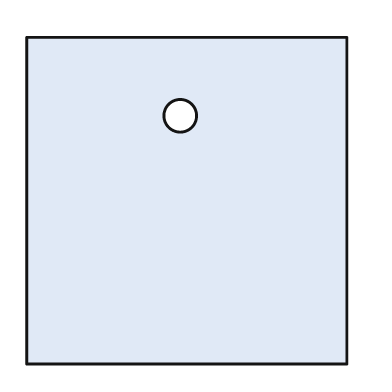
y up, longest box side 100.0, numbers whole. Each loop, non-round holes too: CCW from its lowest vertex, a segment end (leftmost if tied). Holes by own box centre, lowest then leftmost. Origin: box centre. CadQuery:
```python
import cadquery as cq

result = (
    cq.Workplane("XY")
    .moveTo(-49.0, -50.0)
    .lineTo(49.0, -50.0)
    .lineTo(49.0, 50.0)
    .lineTo(-49.0, 50.0)
    .close()
    .moveTo(-2.0, 26.0)
    .circle(5.0)
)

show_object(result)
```